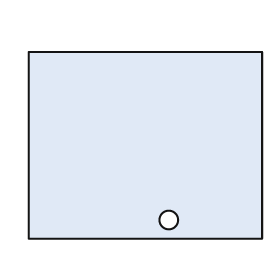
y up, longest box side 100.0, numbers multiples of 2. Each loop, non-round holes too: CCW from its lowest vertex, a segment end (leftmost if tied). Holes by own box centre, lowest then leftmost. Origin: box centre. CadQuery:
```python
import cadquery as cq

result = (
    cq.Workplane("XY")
    .moveTo(-50.0, -40.0)
    .lineTo(50.0, -40.0)
    .lineTo(50.0, 40.0)
    .lineTo(-50.0, 40.0)
    .close()
    .moveTo(10.0, -32.0)
    .circle(4.0)
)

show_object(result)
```